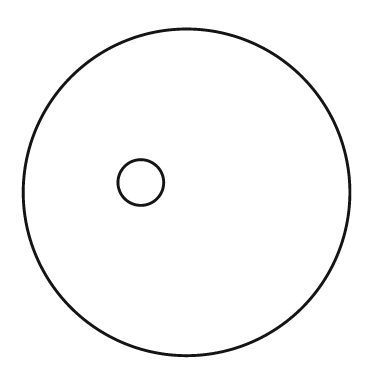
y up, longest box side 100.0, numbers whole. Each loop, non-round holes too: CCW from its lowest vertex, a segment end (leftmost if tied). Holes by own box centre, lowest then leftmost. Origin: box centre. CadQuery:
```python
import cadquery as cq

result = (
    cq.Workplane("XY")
    .moveTo(0.0, 0.0)
    .circle(50.0)
    .moveTo(-14.0, 3.0)
    .circle(7.0)
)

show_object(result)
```